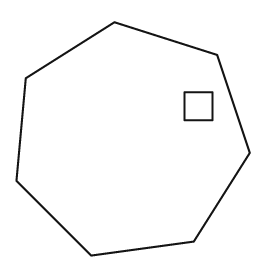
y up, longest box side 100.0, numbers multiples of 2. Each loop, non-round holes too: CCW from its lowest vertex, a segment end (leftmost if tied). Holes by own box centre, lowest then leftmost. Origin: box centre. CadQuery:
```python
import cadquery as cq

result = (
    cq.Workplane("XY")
    .moveTo(-18.0, -50.0)
    .lineTo(26.0, -44.0)
    .lineTo(50.0, -6.0)
    .lineTo(36.0, 36.0)
    .lineTo(-8.0, 50.0)
    .lineTo(-46.0, 26.0)
    .lineTo(-50.0, -18.0)
    .close()
    .moveTo(22.0, 8.0)
    .lineTo(34.0, 8.0)
    .lineTo(34.0, 20.0)
    .lineTo(22.0, 20.0)
    .close()
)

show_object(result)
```